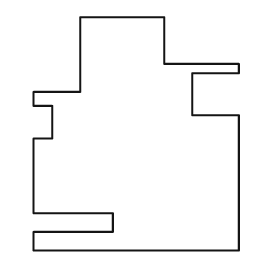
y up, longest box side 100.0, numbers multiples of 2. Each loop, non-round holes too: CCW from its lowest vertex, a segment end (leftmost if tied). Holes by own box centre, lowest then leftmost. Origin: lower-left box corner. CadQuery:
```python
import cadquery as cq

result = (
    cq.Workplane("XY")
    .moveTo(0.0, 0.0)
    .lineTo(88.0, 0.0)
    .lineTo(88.0, 58.0)
    .lineTo(68.0, 58.0)
    .lineTo(68.0, 76.0)
    .lineTo(88.0, 76.0)
    .lineTo(88.0, 80.0)
    .lineTo(56.0, 80.0)
    .lineTo(56.0, 100.0)
    .lineTo(20.0, 100.0)
    .lineTo(20.0, 68.0)
    .lineTo(0.0, 68.0)
    .lineTo(0.0, 62.0)
    .lineTo(8.0, 62.0)
    .lineTo(8.0, 48.0)
    .lineTo(0.0, 48.0)
    .lineTo(0.0, 16.0)
    .lineTo(34.0, 16.0)
    .lineTo(34.0, 8.0)
    .lineTo(0.0, 8.0)
    .close()
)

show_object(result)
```